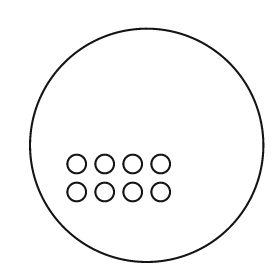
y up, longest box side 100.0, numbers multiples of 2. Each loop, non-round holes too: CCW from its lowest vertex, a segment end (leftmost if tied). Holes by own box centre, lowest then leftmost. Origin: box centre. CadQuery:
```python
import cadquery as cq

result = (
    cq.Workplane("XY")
    .moveTo(0.0, 0.0)
    .circle(50.0)
    .moveTo(-30.0, -20.0)
    .circle(4.0)
    .moveTo(-18.0, -20.0)
    .circle(4.0)
    .moveTo(-6.0, -20.0)
    .circle(4.0)
    .moveTo(6.0, -20.0)
    .circle(4.0)
    .moveTo(-30.0, -8.0)
    .circle(4.0)
    .moveTo(-18.0, -8.0)
    .circle(4.0)
    .moveTo(-6.0, -8.0)
    .circle(4.0)
    .moveTo(6.0, -8.0)
    .circle(4.0)
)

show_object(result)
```